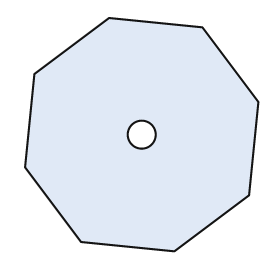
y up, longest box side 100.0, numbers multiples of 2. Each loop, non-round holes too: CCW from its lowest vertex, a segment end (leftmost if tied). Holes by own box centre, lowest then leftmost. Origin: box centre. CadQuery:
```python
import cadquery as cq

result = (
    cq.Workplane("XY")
    .moveTo(14.0, -50.0)
    .lineTo(46.0, -26.0)
    .lineTo(50.0, 14.0)
    .lineTo(26.0, 46.0)
    .lineTo(-14.0, 50.0)
    .lineTo(-46.0, 26.0)
    .lineTo(-50.0, -14.0)
    .lineTo(-26.0, -46.0)
    .close()
    .moveTo(0.0, 0.0)
    .circle(6.0)
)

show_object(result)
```